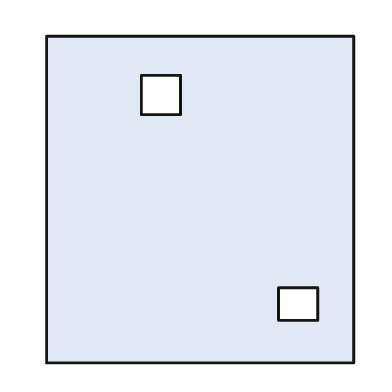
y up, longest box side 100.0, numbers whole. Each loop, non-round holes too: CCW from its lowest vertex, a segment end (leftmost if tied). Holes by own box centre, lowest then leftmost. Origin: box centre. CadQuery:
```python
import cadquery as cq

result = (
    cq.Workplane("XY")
    .moveTo(-47.0, -50.0)
    .lineTo(47.0, -50.0)
    .lineTo(47.0, 50.0)
    .lineTo(-47.0, 50.0)
    .close()
    .moveTo(24.0, -37.0)
    .lineTo(36.0, -37.0)
    .lineTo(36.0, -27.0)
    .lineTo(24.0, -27.0)
    .close()
    .moveTo(-18.0, 26.0)
    .lineTo(-6.0, 26.0)
    .lineTo(-6.0, 38.0)
    .lineTo(-18.0, 38.0)
    .close()
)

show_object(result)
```